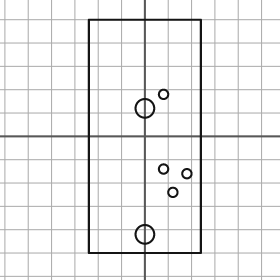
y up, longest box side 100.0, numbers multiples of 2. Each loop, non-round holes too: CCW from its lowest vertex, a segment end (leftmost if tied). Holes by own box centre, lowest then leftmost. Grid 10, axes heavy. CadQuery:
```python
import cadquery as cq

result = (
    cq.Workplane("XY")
    .moveTo(-24.0, -50.0)
    .lineTo(24.0, -50.0)
    .lineTo(24.0, 50.0)
    .lineTo(-24.0, 50.0)
    .close()
    .moveTo(0.0, -42.0)
    .circle(4.0)
    .moveTo(12.0, -24.0)
    .circle(2.0)
    .moveTo(18.0, -16.0)
    .circle(2.0)
    .moveTo(8.0, -14.0)
    .circle(2.0)
    .moveTo(0.0, 12.0)
    .circle(4.0)
    .moveTo(8.0, 18.0)
    .circle(2.0)
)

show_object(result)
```